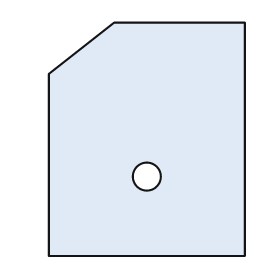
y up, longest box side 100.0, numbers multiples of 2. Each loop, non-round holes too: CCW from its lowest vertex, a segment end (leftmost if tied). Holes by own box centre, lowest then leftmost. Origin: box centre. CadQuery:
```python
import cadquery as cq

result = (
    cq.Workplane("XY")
    .moveTo(-42.0, -50.0)
    .lineTo(42.0, -50.0)
    .lineTo(42.0, 50.0)
    .lineTo(-14.0, 50.0)
    .lineTo(-42.0, 28.0)
    .close()
    .moveTo(0.0, -16.0)
    .circle(6.0)
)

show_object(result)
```